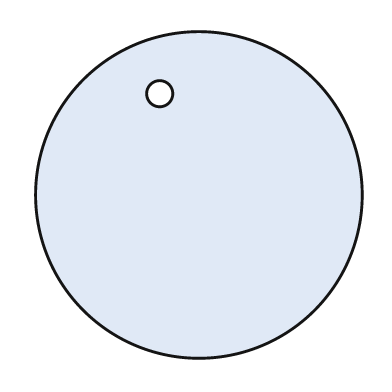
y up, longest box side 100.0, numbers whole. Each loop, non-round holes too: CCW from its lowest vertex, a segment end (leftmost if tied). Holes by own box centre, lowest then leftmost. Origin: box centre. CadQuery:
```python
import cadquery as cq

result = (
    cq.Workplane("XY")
    .moveTo(0.0, 0.0)
    .circle(50.0)
    .moveTo(-12.0, 31.0)
    .circle(4.0)
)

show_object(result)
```